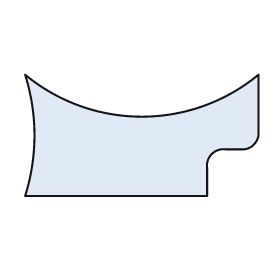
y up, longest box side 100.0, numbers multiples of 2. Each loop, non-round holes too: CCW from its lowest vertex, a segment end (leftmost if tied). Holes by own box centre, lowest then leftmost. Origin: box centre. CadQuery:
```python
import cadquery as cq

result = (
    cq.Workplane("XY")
    .moveTo(-50.0, -26.0)
    .lineTo(28.0, -26.0)
    .lineTo(28.0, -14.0)
    .threePointArc((30.0, -8.0), (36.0, -6.0))
    .lineTo(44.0, -6.0)
    .threePointArc((48.0, -4.0), (50.0, 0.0))
    .lineTo(50.0, 26.0)
    .threePointArc((0.0, 8.0), (-50.0, 26.0))
    .threePointArc((-46.0, 0.0), (-50.0, -26.0))
    .close()
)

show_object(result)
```